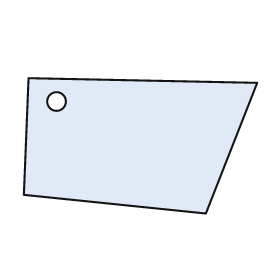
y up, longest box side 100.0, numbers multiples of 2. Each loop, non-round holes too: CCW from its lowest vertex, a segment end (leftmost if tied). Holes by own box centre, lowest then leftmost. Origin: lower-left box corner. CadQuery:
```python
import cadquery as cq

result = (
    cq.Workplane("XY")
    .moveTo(78.0, 0.0)
    .lineTo(100.0, 56.0)
    .lineTo(2.0, 58.0)
    .lineTo(0.0, 8.0)
    .close()
    .moveTo(14.0, 48.0)
    .circle(4.0)
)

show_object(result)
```